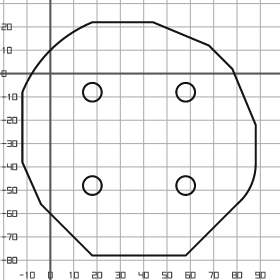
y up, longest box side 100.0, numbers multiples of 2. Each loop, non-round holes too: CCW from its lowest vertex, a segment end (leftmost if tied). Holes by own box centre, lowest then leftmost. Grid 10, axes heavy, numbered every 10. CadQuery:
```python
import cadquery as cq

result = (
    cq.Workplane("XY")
    .moveTo(18.0, -78.0)
    .lineTo(58.0, -78.0)
    .lineTo(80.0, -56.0)
    .threePointArc((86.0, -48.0), (88.0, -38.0))
    .lineTo(88.0, -22.0)
    .lineTo(78.0, 2.0)
    .lineTo(68.0, 12.0)
    .lineTo(44.0, 22.0)
    .lineTo(18.0, 22.0)
    .threePointArc((0.0, 10.0), (-12.0, -8.0))
    .lineTo(-12.0, -38.0)
    .lineTo(-4.0, -56.0)
    .close()
    .moveTo(18.0, -48.0)
    .circle(4.0)
    .moveTo(58.0, -48.0)
    .circle(4.0)
    .moveTo(18.0, -8.0)
    .circle(4.0)
    .moveTo(58.0, -8.0)
    .circle(4.0)
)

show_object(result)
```